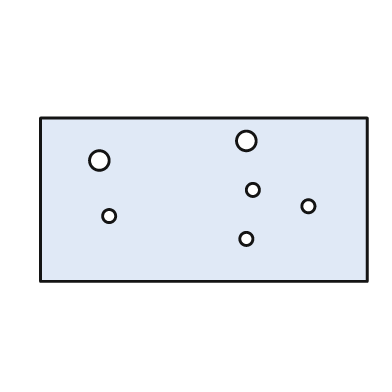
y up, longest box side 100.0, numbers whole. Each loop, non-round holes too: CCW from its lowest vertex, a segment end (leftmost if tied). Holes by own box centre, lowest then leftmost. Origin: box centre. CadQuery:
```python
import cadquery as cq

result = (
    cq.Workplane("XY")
    .moveTo(-50.0, -25.0)
    .lineTo(50.0, -25.0)
    .lineTo(50.0, 25.0)
    .lineTo(-50.0, 25.0)
    .close()
    .moveTo(13.0, -12.0)
    .circle(2.0)
    .moveTo(-29.0, -5.0)
    .circle(2.0)
    .moveTo(32.0, -2.0)
    .circle(2.0)
    .moveTo(15.0, 3.0)
    .circle(2.0)
    .moveTo(-32.0, 12.0)
    .circle(3.0)
    .moveTo(13.0, 18.0)
    .circle(3.0)
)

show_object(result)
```